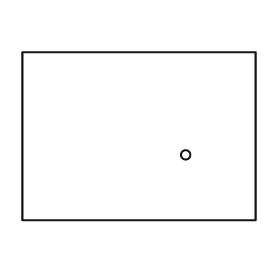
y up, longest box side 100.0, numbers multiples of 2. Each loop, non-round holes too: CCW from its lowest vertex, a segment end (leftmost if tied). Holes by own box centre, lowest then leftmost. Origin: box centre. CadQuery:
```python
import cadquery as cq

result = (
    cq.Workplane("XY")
    .moveTo(-50.0, -36.0)
    .lineTo(50.0, -36.0)
    .lineTo(50.0, 36.0)
    .lineTo(-50.0, 36.0)
    .close()
    .moveTo(20.0, -8.0)
    .circle(2.0)
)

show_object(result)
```